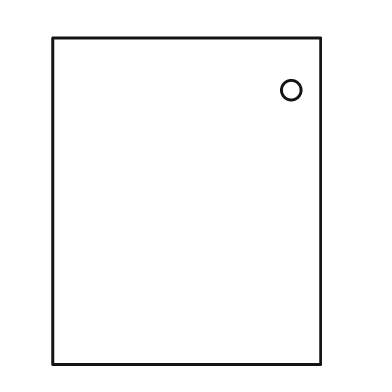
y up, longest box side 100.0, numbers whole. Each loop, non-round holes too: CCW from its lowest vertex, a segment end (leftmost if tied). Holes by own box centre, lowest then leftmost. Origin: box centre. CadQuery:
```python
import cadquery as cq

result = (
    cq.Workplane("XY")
    .moveTo(-41.0, -50.0)
    .lineTo(41.0, -50.0)
    .lineTo(41.0, 50.0)
    .lineTo(-41.0, 50.0)
    .close()
    .moveTo(32.0, 34.0)
    .circle(3.0)
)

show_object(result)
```